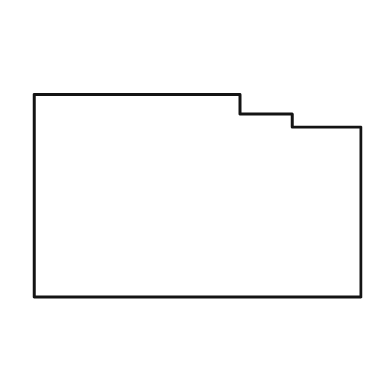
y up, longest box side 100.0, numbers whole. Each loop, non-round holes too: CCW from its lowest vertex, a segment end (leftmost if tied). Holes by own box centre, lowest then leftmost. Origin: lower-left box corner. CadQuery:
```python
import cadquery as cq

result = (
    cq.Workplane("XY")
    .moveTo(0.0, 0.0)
    .lineTo(100.0, 0.0)
    .lineTo(100.0, 52.0)
    .lineTo(79.0, 52.0)
    .lineTo(79.0, 56.0)
    .lineTo(63.0, 56.0)
    .lineTo(63.0, 62.0)
    .lineTo(0.0, 62.0)
    .close()
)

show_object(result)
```